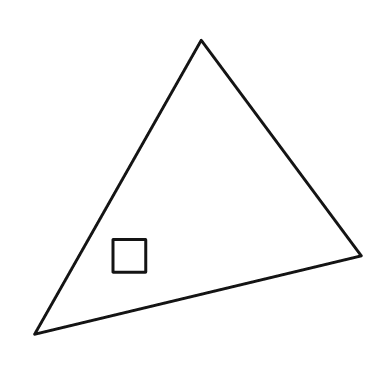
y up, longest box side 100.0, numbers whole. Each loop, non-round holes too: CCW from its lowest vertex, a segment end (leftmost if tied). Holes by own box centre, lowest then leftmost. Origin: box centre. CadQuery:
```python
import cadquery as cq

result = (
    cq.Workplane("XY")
    .moveTo(-50.0, -45.0)
    .lineTo(50.0, -21.0)
    .lineTo(1.0, 45.0)
    .close()
    .moveTo(-26.0, -26.0)
    .lineTo(-16.0, -26.0)
    .lineTo(-16.0, -16.0)
    .lineTo(-26.0, -16.0)
    .close()
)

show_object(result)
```